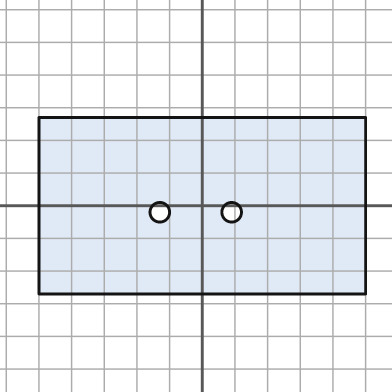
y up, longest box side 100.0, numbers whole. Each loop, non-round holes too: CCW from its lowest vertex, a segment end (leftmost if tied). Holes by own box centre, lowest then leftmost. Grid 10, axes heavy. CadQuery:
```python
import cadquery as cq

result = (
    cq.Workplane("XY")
    .moveTo(-50.0, -27.0)
    .lineTo(50.0, -27.0)
    .lineTo(50.0, 27.0)
    .lineTo(-50.0, 27.0)
    .close()
    .moveTo(-13.0, -2.0)
    .circle(3.0)
    .moveTo(9.0, -2.0)
    .circle(3.0)
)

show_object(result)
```